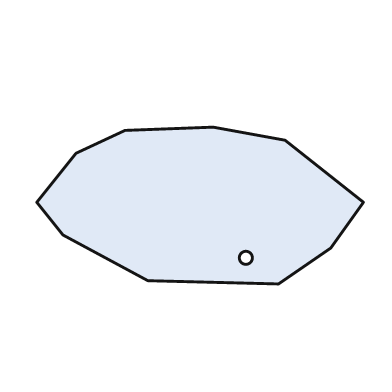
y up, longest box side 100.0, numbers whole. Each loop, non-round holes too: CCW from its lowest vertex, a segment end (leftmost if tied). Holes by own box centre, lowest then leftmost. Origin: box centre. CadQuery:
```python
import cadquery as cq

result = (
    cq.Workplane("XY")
    .moveTo(24.0, -24.0)
    .lineTo(40.0, -13.0)
    .lineTo(50.0, 1.0)
    .lineTo(26.0, 20.0)
    .lineTo(4.0, 24.0)
    .lineTo(-23.0, 23.0)
    .lineTo(-38.0, 16.0)
    .lineTo(-50.0, 1.0)
    .lineTo(-42.0, -9.0)
    .lineTo(-16.0, -23.0)
    .close()
    .moveTo(14.0, -16.0)
    .circle(2.0)
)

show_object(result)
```